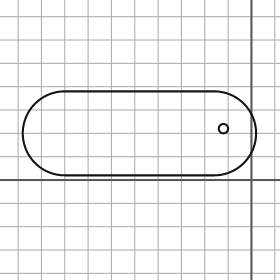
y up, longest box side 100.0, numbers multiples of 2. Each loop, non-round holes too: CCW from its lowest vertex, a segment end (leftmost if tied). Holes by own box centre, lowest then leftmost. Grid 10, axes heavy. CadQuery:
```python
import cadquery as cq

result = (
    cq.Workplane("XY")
    .moveTo(-80.0, 2.0)
    .lineTo(-16.0, 2.0)
    .threePointArc((2.0, 20.0), (-16.0, 38.0))
    .lineTo(-80.0, 38.0)
    .threePointArc((-98.0, 20.0), (-80.0, 2.0))
    .close()
    .moveTo(-12.0, 22.0)
    .circle(2.0)
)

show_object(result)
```